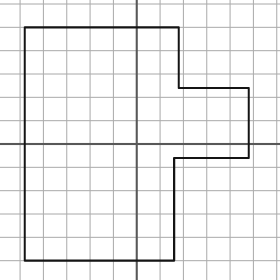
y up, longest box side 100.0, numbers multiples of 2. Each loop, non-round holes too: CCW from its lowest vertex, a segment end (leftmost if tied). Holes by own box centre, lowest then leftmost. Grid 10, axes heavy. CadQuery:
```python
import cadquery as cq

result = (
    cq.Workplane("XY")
    .moveTo(-48.0, -50.0)
    .lineTo(16.0, -50.0)
    .lineTo(16.0, -6.0)
    .lineTo(48.0, -6.0)
    .lineTo(48.0, 24.0)
    .lineTo(18.0, 24.0)
    .lineTo(18.0, 50.0)
    .lineTo(-48.0, 50.0)
    .close()
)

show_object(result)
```